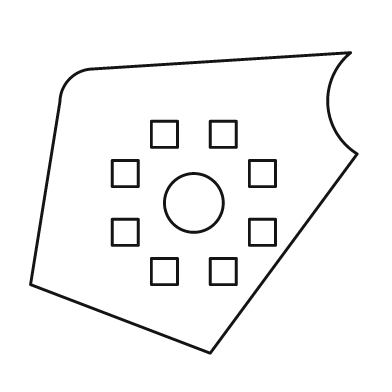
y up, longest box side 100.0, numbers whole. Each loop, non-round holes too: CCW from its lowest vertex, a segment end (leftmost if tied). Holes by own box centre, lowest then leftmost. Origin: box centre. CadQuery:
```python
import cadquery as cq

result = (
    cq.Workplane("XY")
    .moveTo(5.0, -46.0)
    .lineTo(50.0, 15.0)
    .threePointArc((41.0, 30.0), (48.0, 46.0))
    .lineTo(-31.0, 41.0)
    .threePointArc((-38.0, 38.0), (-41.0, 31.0))
    .lineTo(-50.0, -25.0)
    .close()
    .moveTo(-13.0, -25.0)
    .lineTo(-5.0, -25.0)
    .lineTo(-5.0, -17.0)
    .lineTo(-13.0, -17.0)
    .close()
    .moveTo(5.0, -25.0)
    .lineTo(13.0, -25.0)
    .lineTo(13.0, -17.0)
    .lineTo(5.0, -17.0)
    .close()
    .moveTo(-25.0, -13.0)
    .lineTo(-17.0, -13.0)
    .lineTo(-17.0, -5.0)
    .lineTo(-25.0, -5.0)
    .close()
    .moveTo(17.0, -13.0)
    .lineTo(25.0, -13.0)
    .lineTo(25.0, -5.0)
    .lineTo(17.0, -5.0)
    .close()
    .moveTo(0.0, 0.0)
    .circle(9.0)
    .moveTo(-25.0, 5.0)
    .lineTo(-17.0, 5.0)
    .lineTo(-17.0, 13.0)
    .lineTo(-25.0, 13.0)
    .close()
    .moveTo(17.0, 5.0)
    .lineTo(25.0, 5.0)
    .lineTo(25.0, 13.0)
    .lineTo(17.0, 13.0)
    .close()
    .moveTo(-13.0, 17.0)
    .lineTo(-5.0, 17.0)
    .lineTo(-5.0, 25.0)
    .lineTo(-13.0, 25.0)
    .close()
    .moveTo(5.0, 17.0)
    .lineTo(13.0, 17.0)
    .lineTo(13.0, 25.0)
    .lineTo(5.0, 25.0)
    .close()
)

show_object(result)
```